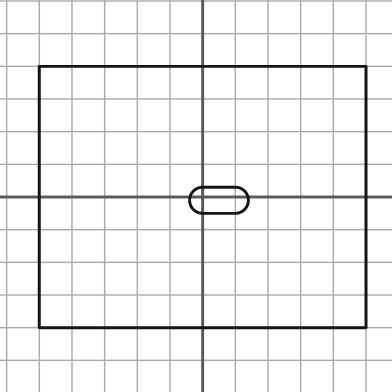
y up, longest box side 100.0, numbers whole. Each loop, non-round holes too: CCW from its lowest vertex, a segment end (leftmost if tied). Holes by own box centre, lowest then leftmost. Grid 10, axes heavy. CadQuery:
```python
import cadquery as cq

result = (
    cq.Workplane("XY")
    .moveTo(-50.0, -40.0)
    .lineTo(50.0, -40.0)
    .lineTo(50.0, 40.0)
    .lineTo(-50.0, 40.0)
    .close()
    .moveTo(0.0, -5.0)
    .lineTo(10.0, -5.0)
    .threePointArc((14.0, -1.0), (10.0, 3.0))
    .lineTo(0.0, 3.0)
    .threePointArc((-4.0, -1.0), (0.0, -5.0))
    .close()
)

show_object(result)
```